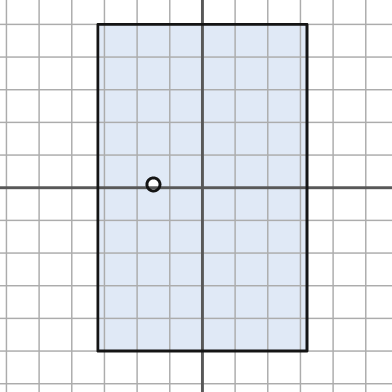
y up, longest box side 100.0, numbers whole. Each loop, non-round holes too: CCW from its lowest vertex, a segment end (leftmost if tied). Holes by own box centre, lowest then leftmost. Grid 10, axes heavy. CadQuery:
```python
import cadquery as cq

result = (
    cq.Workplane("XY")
    .moveTo(-32.0, -50.0)
    .lineTo(32.0, -50.0)
    .lineTo(32.0, 50.0)
    .lineTo(-32.0, 50.0)
    .close()
    .moveTo(-15.0, 1.0)
    .circle(2.0)
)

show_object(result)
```